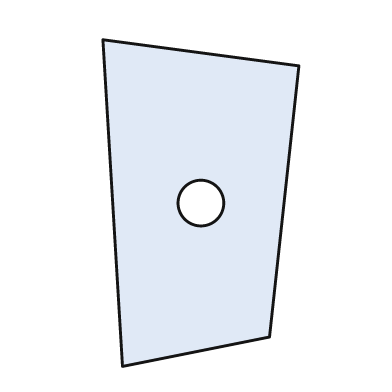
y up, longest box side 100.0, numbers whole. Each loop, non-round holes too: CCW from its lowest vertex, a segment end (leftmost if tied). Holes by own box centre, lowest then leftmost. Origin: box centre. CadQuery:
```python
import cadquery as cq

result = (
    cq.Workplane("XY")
    .moveTo(-24.0, -50.0)
    .lineTo(21.0, -41.0)
    .lineTo(30.0, 42.0)
    .lineTo(-30.0, 50.0)
    .close()
    .moveTo(0.0, 0.0)
    .circle(7.0)
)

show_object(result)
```